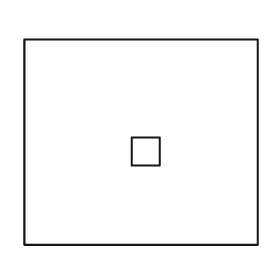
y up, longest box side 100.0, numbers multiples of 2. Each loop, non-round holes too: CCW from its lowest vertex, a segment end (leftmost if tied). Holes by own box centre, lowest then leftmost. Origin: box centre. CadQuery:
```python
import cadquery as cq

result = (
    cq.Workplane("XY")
    .moveTo(-50.0, -44.0)
    .lineTo(50.0, -44.0)
    .lineTo(50.0, 44.0)
    .lineTo(-50.0, 44.0)
    .close()
    .moveTo(-4.0, -10.0)
    .lineTo(8.0, -10.0)
    .lineTo(8.0, 2.0)
    .lineTo(-4.0, 2.0)
    .close()
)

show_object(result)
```